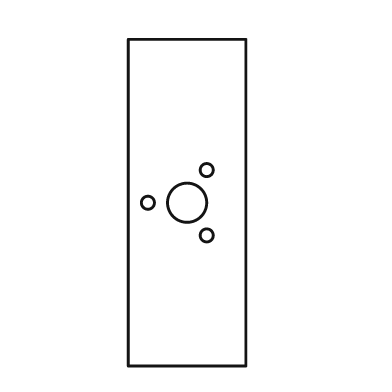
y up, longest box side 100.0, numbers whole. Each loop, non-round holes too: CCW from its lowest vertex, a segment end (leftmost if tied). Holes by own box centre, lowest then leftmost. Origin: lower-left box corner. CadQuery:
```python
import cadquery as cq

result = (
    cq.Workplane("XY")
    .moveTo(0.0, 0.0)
    .lineTo(36.0, 0.0)
    .lineTo(36.0, 100.0)
    .lineTo(0.0, 100.0)
    .close()
    .moveTo(24.0, 40.0)
    .circle(2.0)
    .moveTo(6.0, 50.0)
    .circle(2.0)
    .moveTo(18.0, 50.0)
    .circle(6.0)
    .moveTo(24.0, 60.0)
    .circle(2.0)
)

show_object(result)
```